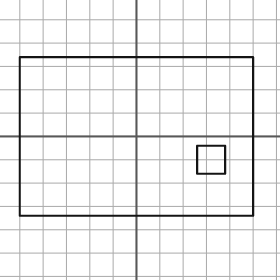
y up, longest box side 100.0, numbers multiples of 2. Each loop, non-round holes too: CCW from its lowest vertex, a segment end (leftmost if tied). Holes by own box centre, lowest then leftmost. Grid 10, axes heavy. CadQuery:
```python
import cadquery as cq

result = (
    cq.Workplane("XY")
    .moveTo(-50.0, -34.0)
    .lineTo(50.0, -34.0)
    .lineTo(50.0, 34.0)
    .lineTo(-50.0, 34.0)
    .close()
    .moveTo(26.0, -16.0)
    .lineTo(38.0, -16.0)
    .lineTo(38.0, -4.0)
    .lineTo(26.0, -4.0)
    .close()
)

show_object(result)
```